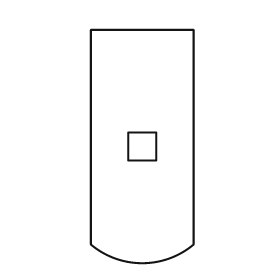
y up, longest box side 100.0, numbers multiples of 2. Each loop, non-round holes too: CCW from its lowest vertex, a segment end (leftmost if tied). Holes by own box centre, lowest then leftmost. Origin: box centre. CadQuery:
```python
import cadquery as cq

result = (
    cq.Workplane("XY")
    .moveTo(-22.0, -42.0)
    .threePointArc((0.0, -50.0), (22.0, -42.0))
    .lineTo(22.0, 50.0)
    .lineTo(-22.0, 50.0)
    .close()
    .moveTo(-6.0, -6.0)
    .lineTo(6.0, -6.0)
    .lineTo(6.0, 6.0)
    .lineTo(-6.0, 6.0)
    .close()
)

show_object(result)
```